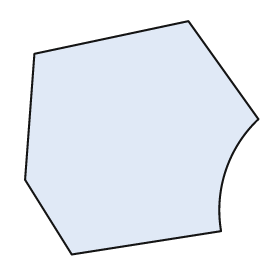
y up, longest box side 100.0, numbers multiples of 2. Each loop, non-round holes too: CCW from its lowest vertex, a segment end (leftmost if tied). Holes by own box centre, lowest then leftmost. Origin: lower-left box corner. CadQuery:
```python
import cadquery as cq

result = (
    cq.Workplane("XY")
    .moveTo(20.0, 0.0)
    .lineTo(84.0, 10.0)
    .threePointArc((86.0, 36.0), (100.0, 58.0))
    .lineTo(70.0, 100.0)
    .lineTo(4.0, 86.0)
    .lineTo(0.0, 32.0)
    .close()
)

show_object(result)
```